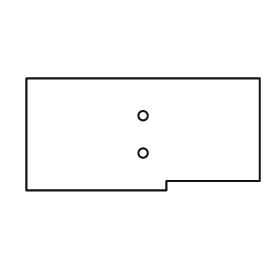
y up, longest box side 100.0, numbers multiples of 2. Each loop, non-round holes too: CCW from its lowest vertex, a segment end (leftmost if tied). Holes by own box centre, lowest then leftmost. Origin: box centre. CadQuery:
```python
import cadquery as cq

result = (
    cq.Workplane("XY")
    .moveTo(-50.0, -24.0)
    .lineTo(10.0, -24.0)
    .lineTo(10.0, -20.0)
    .lineTo(50.0, -20.0)
    .lineTo(50.0, 24.0)
    .lineTo(-50.0, 24.0)
    .close()
    .moveTo(0.0, -8.0)
    .circle(2.0)
    .moveTo(0.0, 8.0)
    .circle(2.0)
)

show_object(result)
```